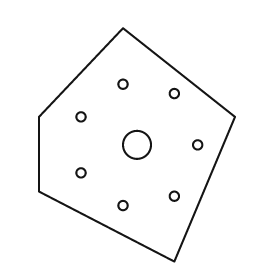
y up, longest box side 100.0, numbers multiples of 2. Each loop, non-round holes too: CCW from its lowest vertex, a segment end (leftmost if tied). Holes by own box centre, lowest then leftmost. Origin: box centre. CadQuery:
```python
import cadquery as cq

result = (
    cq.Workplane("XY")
    .moveTo(16.0, -50.0)
    .lineTo(42.0, 12.0)
    .lineTo(-6.0, 50.0)
    .lineTo(-42.0, 12.0)
    .lineTo(-42.0, -20.0)
    .close()
    .moveTo(-6.0, -26.0)
    .circle(2.0)
    .moveTo(16.0, -22.0)
    .circle(2.0)
    .moveTo(-24.0, -12.0)
    .circle(2.0)
    .moveTo(0.0, 0.0)
    .circle(6.0)
    .moveTo(26.0, 0.0)
    .circle(2.0)
    .moveTo(-24.0, 12.0)
    .circle(2.0)
    .moveTo(16.0, 22.0)
    .circle(2.0)
    .moveTo(-6.0, 26.0)
    .circle(2.0)
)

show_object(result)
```